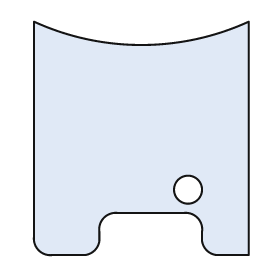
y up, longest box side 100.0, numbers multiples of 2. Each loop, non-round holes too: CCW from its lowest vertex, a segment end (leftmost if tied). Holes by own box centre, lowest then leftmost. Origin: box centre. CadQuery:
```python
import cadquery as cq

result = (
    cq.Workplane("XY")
    .moveTo(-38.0, -50.0)
    .lineTo(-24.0, -50.0)
    .threePointArc((-20.0, -48.0), (-18.0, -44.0))
    .lineTo(-18.0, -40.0)
    .threePointArc((-16.0, -34.0), (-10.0, -32.0))
    .lineTo(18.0, -32.0)
    .threePointArc((24.0, -34.0), (26.0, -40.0))
    .lineTo(26.0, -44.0)
    .threePointArc((28.0, -48.0), (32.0, -50.0))
    .lineTo(46.0, -50.0)
    .lineTo(46.0, 50.0)
    .threePointArc((0.0, 40.0), (-46.0, 50.0))
    .lineTo(-46.0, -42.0)
    .threePointArc((-44.0, -48.0), (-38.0, -50.0))
    .close()
    .moveTo(20.0, -22.0)
    .circle(6.0)
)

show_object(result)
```